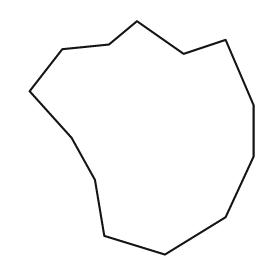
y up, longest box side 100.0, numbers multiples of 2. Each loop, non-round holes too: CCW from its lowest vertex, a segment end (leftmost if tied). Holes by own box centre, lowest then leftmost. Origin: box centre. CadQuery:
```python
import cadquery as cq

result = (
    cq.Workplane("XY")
    .moveTo(10.0, -50.0)
    .lineTo(36.0, -34.0)
    .lineTo(48.0, -8.0)
    .lineTo(48.0, 14.0)
    .lineTo(36.0, 42.0)
    .lineTo(18.0, 36.0)
    .lineTo(-2.0, 50.0)
    .lineTo(-14.0, 40.0)
    .lineTo(-34.0, 38.0)
    .lineTo(-48.0, 20.0)
    .lineTo(-30.0, 0.0)
    .lineTo(-20.0, -18.0)
    .lineTo(-16.0, -42.0)
    .close()
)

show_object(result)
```